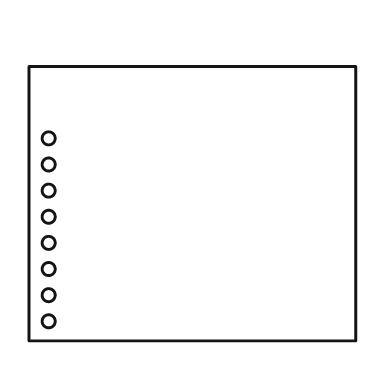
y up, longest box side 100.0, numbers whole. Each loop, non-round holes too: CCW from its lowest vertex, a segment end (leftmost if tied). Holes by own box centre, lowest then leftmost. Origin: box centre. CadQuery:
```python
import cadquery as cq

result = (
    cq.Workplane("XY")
    .moveTo(-50.0, -42.0)
    .lineTo(50.0, -42.0)
    .lineTo(50.0, 42.0)
    .lineTo(-50.0, 42.0)
    .close()
    .moveTo(-44.0, -36.0)
    .circle(2.0)
    .moveTo(-44.0, -28.0)
    .circle(2.0)
    .moveTo(-44.0, -20.0)
    .circle(2.0)
    .moveTo(-44.0, -12.0)
    .circle(2.0)
    .moveTo(-44.0, -4.0)
    .circle(2.0)
    .moveTo(-44.0, 4.0)
    .circle(2.0)
    .moveTo(-44.0, 12.0)
    .circle(2.0)
    .moveTo(-44.0, 20.0)
    .circle(2.0)
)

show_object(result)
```